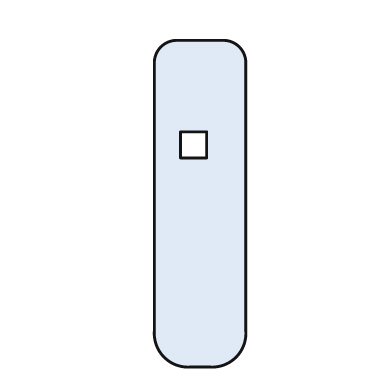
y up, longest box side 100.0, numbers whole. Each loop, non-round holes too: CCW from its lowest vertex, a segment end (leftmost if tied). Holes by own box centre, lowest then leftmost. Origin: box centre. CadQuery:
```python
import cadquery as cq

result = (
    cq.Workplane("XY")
    .moveTo(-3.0, -50.0)
    .lineTo(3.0, -50.0)
    .threePointArc((11.0, -47.0), (14.0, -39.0))
    .lineTo(14.0, 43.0)
    .threePointArc((12.0, 48.0), (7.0, 50.0))
    .lineTo(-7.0, 50.0)
    .threePointArc((-12.0, 48.0), (-14.0, 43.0))
    .lineTo(-14.0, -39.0)
    .threePointArc((-11.0, -47.0), (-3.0, -50.0))
    .close()
    .moveTo(-6.0, 14.0)
    .lineTo(2.0, 14.0)
    .lineTo(2.0, 22.0)
    .lineTo(-6.0, 22.0)
    .close()
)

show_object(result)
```